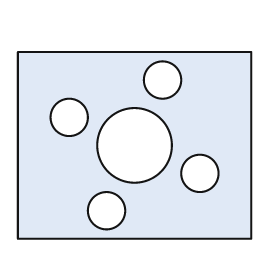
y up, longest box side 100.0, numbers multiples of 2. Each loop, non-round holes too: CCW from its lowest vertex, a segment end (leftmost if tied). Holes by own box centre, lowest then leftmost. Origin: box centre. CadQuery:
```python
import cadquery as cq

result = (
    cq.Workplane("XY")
    .moveTo(-50.0, -40.0)
    .lineTo(50.0, -40.0)
    .lineTo(50.0, 40.0)
    .lineTo(-50.0, 40.0)
    .close()
    .moveTo(-12.0, -28.0)
    .circle(8.0)
    .moveTo(28.0, -12.0)
    .circle(8.0)
    .moveTo(0.0, 0.0)
    .circle(16.0)
    .moveTo(-28.0, 12.0)
    .circle(8.0)
    .moveTo(12.0, 28.0)
    .circle(8.0)
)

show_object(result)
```